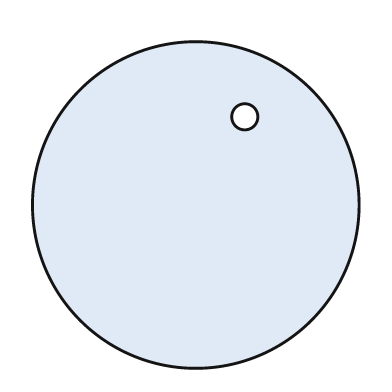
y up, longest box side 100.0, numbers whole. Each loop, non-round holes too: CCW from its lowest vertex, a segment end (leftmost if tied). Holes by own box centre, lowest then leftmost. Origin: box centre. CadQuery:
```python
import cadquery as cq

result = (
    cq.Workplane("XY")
    .moveTo(0.0, 0.0)
    .circle(50.0)
    .moveTo(15.0, 27.0)
    .circle(4.0)
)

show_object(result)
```